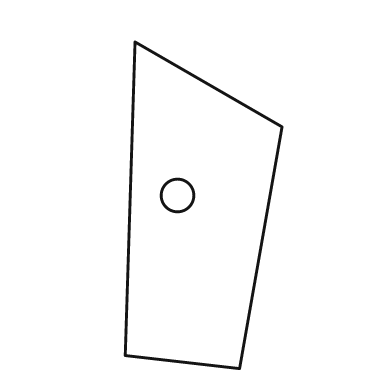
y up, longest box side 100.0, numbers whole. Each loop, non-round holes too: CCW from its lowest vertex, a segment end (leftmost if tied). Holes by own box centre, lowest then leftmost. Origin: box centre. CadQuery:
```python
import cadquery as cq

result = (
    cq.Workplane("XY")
    .moveTo(11.0, -50.0)
    .lineTo(24.0, 24.0)
    .lineTo(-21.0, 50.0)
    .lineTo(-24.0, -46.0)
    .close()
    .moveTo(-8.0, 3.0)
    .circle(5.0)
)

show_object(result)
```